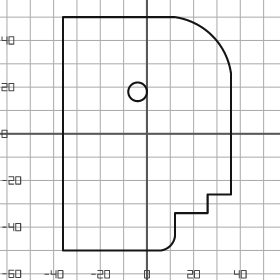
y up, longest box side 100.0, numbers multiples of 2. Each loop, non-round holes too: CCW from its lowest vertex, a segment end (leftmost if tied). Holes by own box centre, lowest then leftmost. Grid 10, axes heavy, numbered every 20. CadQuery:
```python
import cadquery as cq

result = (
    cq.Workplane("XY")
    .moveTo(-36.0, -50.0)
    .lineTo(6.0, -50.0)
    .threePointArc((10.0, -48.0), (12.0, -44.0))
    .lineTo(12.0, -34.0)
    .lineTo(26.0, -34.0)
    .lineTo(26.0, -26.0)
    .lineTo(36.0, -26.0)
    .lineTo(36.0, 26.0)
    .threePointArc((28.0, 42.0), (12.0, 50.0))
    .lineTo(-36.0, 50.0)
    .close()
    .moveTo(-4.0, 18.0)
    .circle(4.0)
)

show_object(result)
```